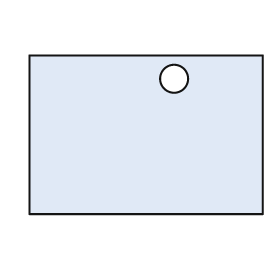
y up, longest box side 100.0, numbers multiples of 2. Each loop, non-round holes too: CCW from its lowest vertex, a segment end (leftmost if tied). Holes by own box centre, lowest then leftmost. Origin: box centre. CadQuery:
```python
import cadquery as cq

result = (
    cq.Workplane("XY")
    .moveTo(-50.0, -34.0)
    .lineTo(50.0, -34.0)
    .lineTo(50.0, 34.0)
    .lineTo(-50.0, 34.0)
    .close()
    .moveTo(12.0, 24.0)
    .circle(6.0)
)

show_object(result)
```